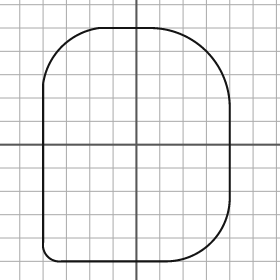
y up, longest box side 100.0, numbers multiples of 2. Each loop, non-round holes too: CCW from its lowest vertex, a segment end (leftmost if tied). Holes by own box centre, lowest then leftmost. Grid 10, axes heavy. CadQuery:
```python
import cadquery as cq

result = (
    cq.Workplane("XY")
    .moveTo(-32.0, -50.0)
    .lineTo(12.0, -50.0)
    .threePointArc((32.0, -42.0), (40.0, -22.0))
    .lineTo(40.0, 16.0)
    .threePointArc((30.0, 40.0), (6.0, 50.0))
    .lineTo(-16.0, 50.0)
    .threePointArc((-32.0, 42.0), (-40.0, 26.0))
    .lineTo(-40.0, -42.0)
    .threePointArc((-38.0, -48.0), (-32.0, -50.0))
    .close()
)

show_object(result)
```